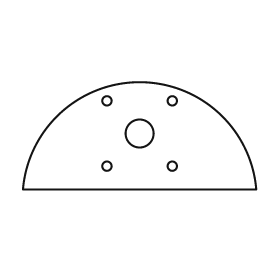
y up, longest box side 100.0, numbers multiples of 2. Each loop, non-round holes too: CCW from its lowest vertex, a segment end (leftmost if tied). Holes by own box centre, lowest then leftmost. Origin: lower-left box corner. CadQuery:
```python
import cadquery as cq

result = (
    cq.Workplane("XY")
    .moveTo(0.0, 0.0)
    .lineTo(100.0, 0.0)
    .threePointArc((50.0, 46.0), (0.0, 0.0))
    .close()
    .moveTo(36.0, 10.0)
    .circle(2.0)
    .moveTo(64.0, 10.0)
    .circle(2.0)
    .moveTo(50.0, 24.0)
    .circle(6.0)
    .moveTo(36.0, 38.0)
    .circle(2.0)
    .moveTo(64.0, 38.0)
    .circle(2.0)
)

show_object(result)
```